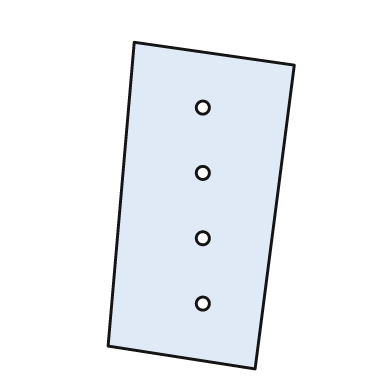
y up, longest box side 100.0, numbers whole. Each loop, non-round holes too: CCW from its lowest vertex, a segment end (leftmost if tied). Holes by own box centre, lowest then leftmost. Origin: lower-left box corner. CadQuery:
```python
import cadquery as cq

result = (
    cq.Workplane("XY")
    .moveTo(45.0, 0.0)
    .lineTo(57.0, 93.0)
    .lineTo(8.0, 100.0)
    .lineTo(0.0, 7.0)
    .close()
    .moveTo(29.0, 20.0)
    .circle(2.0)
    .moveTo(29.0, 40.0)
    .circle(2.0)
    .moveTo(29.0, 60.0)
    .circle(2.0)
    .moveTo(29.0, 80.0)
    .circle(2.0)
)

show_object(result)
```